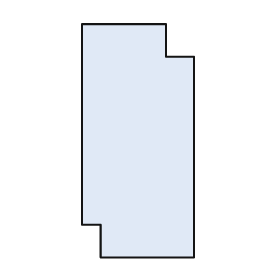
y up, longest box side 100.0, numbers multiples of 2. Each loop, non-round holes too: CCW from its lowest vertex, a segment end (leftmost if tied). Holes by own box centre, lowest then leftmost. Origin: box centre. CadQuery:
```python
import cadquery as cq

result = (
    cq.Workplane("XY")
    .moveTo(-16.0, -50.0)
    .lineTo(24.0, -50.0)
    .lineTo(24.0, 36.0)
    .lineTo(12.0, 36.0)
    .lineTo(12.0, 50.0)
    .lineTo(-24.0, 50.0)
    .lineTo(-24.0, -36.0)
    .lineTo(-16.0, -36.0)
    .close()
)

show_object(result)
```